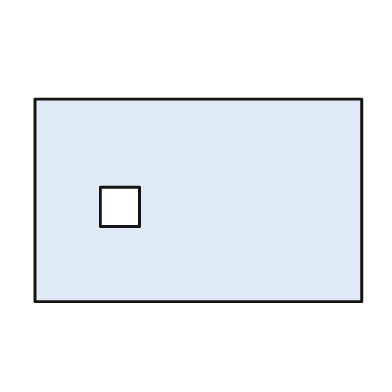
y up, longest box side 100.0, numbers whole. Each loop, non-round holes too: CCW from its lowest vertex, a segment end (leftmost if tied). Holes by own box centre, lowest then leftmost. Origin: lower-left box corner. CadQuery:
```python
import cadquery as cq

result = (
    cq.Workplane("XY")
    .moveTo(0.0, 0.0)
    .lineTo(100.0, 0.0)
    .lineTo(100.0, 62.0)
    .lineTo(0.0, 62.0)
    .close()
    .moveTo(20.0, 23.0)
    .lineTo(32.0, 23.0)
    .lineTo(32.0, 35.0)
    .lineTo(20.0, 35.0)
    .close()
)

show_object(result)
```